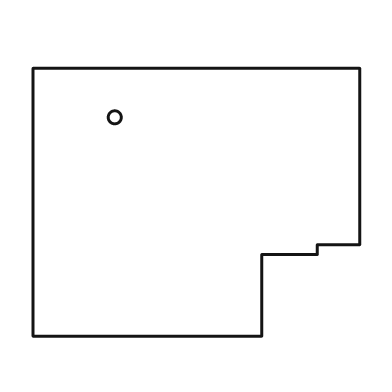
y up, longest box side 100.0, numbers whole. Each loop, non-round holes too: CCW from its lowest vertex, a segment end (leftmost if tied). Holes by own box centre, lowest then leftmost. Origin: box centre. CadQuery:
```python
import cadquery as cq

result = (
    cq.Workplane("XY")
    .moveTo(-50.0, -41.0)
    .lineTo(20.0, -41.0)
    .lineTo(20.0, -16.0)
    .lineTo(37.0, -16.0)
    .lineTo(37.0, -13.0)
    .lineTo(50.0, -13.0)
    .lineTo(50.0, 41.0)
    .lineTo(-50.0, 41.0)
    .close()
    .moveTo(-25.0, 26.0)
    .circle(2.0)
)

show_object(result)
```